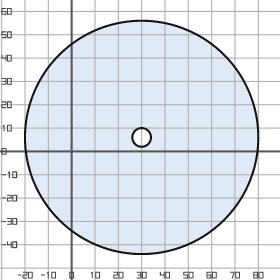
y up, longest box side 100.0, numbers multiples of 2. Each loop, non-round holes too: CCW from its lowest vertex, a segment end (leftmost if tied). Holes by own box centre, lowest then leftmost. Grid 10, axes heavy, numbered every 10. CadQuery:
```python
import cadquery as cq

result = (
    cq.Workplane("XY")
    .moveTo(30.0, 6.0)
    .circle(50.0)
    .moveTo(30.0, 6.0)
    .circle(4.0)
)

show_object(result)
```